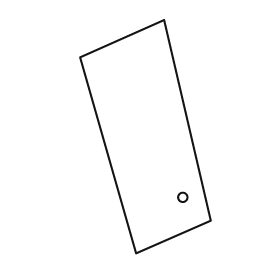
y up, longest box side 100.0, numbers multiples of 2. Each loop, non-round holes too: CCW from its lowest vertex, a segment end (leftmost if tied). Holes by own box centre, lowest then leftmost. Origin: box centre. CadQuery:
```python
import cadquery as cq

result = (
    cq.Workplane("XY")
    .moveTo(-4.0, -50.0)
    .lineTo(28.0, -36.0)
    .lineTo(8.0, 50.0)
    .lineTo(-28.0, 34.0)
    .close()
    .moveTo(16.0, -26.0)
    .circle(2.0)
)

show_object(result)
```